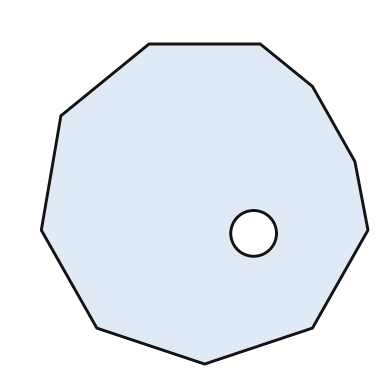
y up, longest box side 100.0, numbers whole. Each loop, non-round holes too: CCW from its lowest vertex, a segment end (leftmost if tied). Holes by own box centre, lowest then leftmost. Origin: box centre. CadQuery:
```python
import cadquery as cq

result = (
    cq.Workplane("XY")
    .moveTo(0.0, -49.0)
    .lineTo(33.0, -38.0)
    .lineTo(50.0, -8.0)
    .lineTo(46.0, 13.0)
    .lineTo(33.0, 36.0)
    .lineTo(17.0, 49.0)
    .lineTo(-17.0, 49.0)
    .lineTo(-44.0, 27.0)
    .lineTo(-50.0, -8.0)
    .lineTo(-33.0, -38.0)
    .close()
    .moveTo(15.0, -9.0)
    .circle(7.0)
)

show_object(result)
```